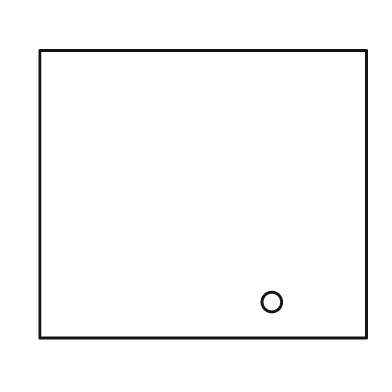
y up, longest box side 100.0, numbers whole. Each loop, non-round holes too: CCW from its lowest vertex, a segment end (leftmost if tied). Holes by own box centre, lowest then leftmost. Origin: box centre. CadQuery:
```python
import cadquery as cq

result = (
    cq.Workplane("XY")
    .moveTo(-50.0, -44.0)
    .lineTo(50.0, -44.0)
    .lineTo(50.0, 44.0)
    .lineTo(-50.0, 44.0)
    .close()
    .moveTo(21.0, -33.0)
    .circle(3.0)
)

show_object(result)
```